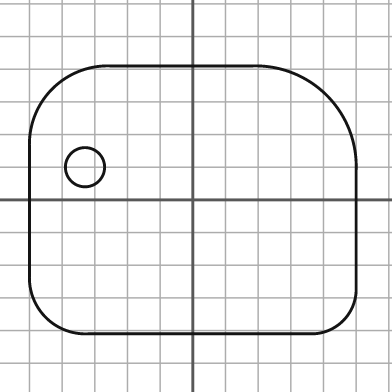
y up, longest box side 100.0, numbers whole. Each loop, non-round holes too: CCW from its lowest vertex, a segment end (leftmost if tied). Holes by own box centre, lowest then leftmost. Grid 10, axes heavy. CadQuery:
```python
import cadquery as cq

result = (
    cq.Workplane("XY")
    .moveTo(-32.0, -41.0)
    .lineTo(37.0, -41.0)
    .threePointArc((46.0, -37.0), (50.0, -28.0))
    .lineTo(50.0, 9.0)
    .threePointArc((41.0, 32.0), (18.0, 41.0))
    .lineTo(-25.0, 41.0)
    .threePointArc((-43.0, 34.0), (-50.0, 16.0))
    .lineTo(-50.0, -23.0)
    .threePointArc((-45.0, -36.0), (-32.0, -41.0))
    .close()
    .moveTo(-33.0, 10.0)
    .circle(6.0)
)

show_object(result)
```